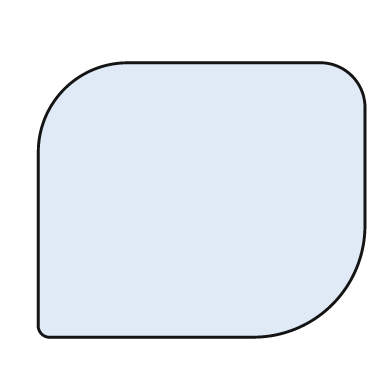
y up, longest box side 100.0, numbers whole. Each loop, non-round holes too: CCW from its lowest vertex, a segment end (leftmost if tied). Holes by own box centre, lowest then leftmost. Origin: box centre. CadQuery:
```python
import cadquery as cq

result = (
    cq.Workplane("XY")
    .moveTo(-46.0, -42.0)
    .lineTo(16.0, -42.0)
    .threePointArc((40.0, -32.0), (50.0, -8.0))
    .lineTo(50.0, 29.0)
    .threePointArc((46.0, 38.0), (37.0, 42.0))
    .lineTo(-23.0, 42.0)
    .threePointArc((-42.0, 34.0), (-50.0, 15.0))
    .lineTo(-50.0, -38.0)
    .threePointArc((-49.0, -41.0), (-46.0, -42.0))
    .close()
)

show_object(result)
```